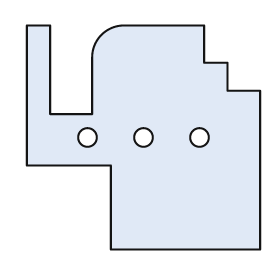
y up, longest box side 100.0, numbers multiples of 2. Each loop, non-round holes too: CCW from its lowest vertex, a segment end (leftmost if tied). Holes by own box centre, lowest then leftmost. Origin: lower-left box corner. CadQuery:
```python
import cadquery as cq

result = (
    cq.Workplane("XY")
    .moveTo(36.0, 0.0)
    .lineTo(100.0, 0.0)
    .lineTo(100.0, 68.0)
    .lineTo(86.0, 68.0)
    .lineTo(86.0, 80.0)
    .lineTo(76.0, 80.0)
    .lineTo(76.0, 96.0)
    .lineTo(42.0, 96.0)
    .threePointArc((32.0, 92.0), (28.0, 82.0))
    .lineTo(28.0, 58.0)
    .lineTo(10.0, 58.0)
    .lineTo(10.0, 96.0)
    .lineTo(0.0, 96.0)
    .lineTo(0.0, 36.0)
    .lineTo(36.0, 36.0)
    .close()
    .moveTo(26.0, 48.0)
    .circle(4.0)
    .moveTo(50.0, 48.0)
    .circle(4.0)
    .moveTo(74.0, 48.0)
    .circle(4.0)
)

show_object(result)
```